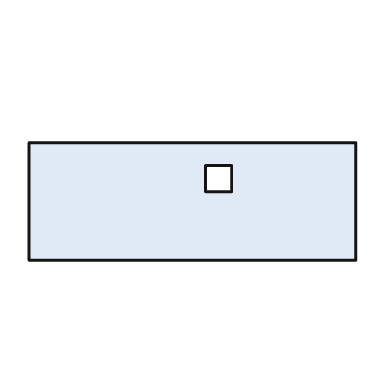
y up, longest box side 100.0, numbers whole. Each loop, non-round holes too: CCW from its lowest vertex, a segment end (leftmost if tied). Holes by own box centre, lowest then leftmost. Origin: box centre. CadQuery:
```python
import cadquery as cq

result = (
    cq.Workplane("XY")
    .moveTo(-50.0, -18.0)
    .lineTo(50.0, -18.0)
    .lineTo(50.0, 18.0)
    .lineTo(-50.0, 18.0)
    .close()
    .moveTo(4.0, 3.0)
    .lineTo(12.0, 3.0)
    .lineTo(12.0, 11.0)
    .lineTo(4.0, 11.0)
    .close()
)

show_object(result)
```